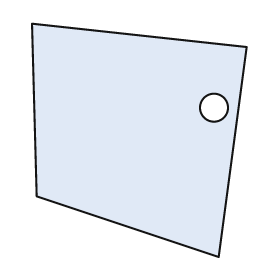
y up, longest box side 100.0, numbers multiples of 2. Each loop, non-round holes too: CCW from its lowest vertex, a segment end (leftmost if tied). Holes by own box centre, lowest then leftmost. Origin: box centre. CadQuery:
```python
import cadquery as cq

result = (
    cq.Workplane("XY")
    .moveTo(34.0, -50.0)
    .lineTo(46.0, 40.0)
    .lineTo(-46.0, 50.0)
    .lineTo(-44.0, -24.0)
    .close()
    .moveTo(32.0, 14.0)
    .circle(6.0)
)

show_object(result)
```